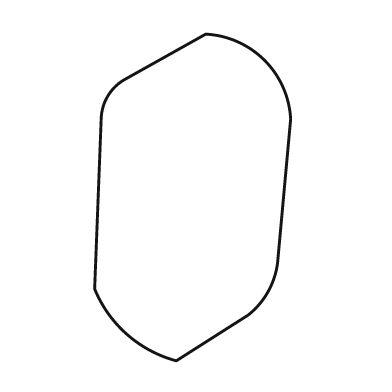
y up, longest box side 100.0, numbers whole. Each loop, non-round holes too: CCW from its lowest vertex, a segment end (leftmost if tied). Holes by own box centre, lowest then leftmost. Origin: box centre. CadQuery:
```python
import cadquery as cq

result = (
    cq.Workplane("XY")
    .moveTo(-5.0, -50.0)
    .lineTo(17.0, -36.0)
    .threePointArc((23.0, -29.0), (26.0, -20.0))
    .lineTo(30.0, 24.0)
    .threePointArc((22.0, 42.0), (4.0, 50.0))
    .lineTo(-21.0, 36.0)
    .threePointArc((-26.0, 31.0), (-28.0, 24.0))
    .lineTo(-30.0, -28.0)
    .threePointArc((-20.0, -42.0), (-5.0, -50.0))
    .close()
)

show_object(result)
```